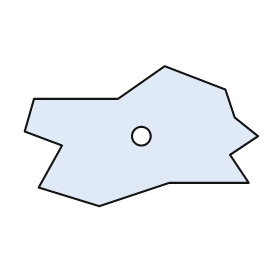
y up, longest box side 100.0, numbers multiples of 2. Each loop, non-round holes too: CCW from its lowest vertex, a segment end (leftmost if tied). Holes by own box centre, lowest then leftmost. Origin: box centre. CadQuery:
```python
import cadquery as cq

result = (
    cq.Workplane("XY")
    .moveTo(-18.0, -30.0)
    .lineTo(12.0, -20.0)
    .lineTo(46.0, -20.0)
    .lineTo(38.0, -8.0)
    .lineTo(50.0, 0.0)
    .lineTo(40.0, 8.0)
    .lineTo(36.0, 20.0)
    .lineTo(10.0, 30.0)
    .lineTo(-10.0, 16.0)
    .lineTo(-46.0, 16.0)
    .lineTo(-50.0, 2.0)
    .lineTo(-34.0, -4.0)
    .lineTo(-44.0, -22.0)
    .close()
    .moveTo(0.0, 0.0)
    .circle(4.0)
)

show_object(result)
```